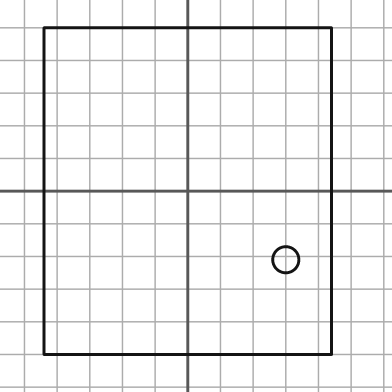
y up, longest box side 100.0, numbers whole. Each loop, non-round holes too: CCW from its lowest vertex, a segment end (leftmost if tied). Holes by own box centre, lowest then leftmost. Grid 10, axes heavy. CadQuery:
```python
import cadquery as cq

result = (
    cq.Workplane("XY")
    .moveTo(-44.0, -50.0)
    .lineTo(44.0, -50.0)
    .lineTo(44.0, 50.0)
    .lineTo(-44.0, 50.0)
    .close()
    .moveTo(30.0, -21.0)
    .circle(4.0)
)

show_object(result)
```